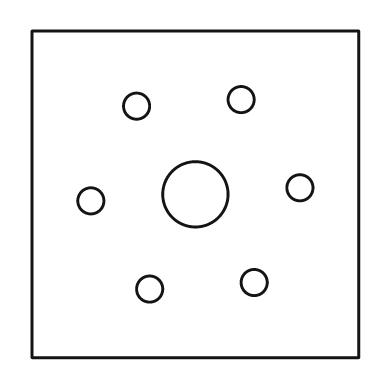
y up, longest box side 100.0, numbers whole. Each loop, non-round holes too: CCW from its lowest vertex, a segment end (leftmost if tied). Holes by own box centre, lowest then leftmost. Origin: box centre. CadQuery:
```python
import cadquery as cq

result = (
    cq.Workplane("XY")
    .moveTo(-50.0, -50.0)
    .lineTo(50.0, -50.0)
    .lineTo(50.0, 50.0)
    .lineTo(-50.0, 50.0)
    .close()
    .moveTo(-14.0, -29.0)
    .circle(4.0)
    .moveTo(18.0, -27.0)
    .circle(4.0)
    .moveTo(-32.0, -2.0)
    .circle(4.0)
    .moveTo(0.0, 0.0)
    .circle(10.0)
    .moveTo(32.0, 2.0)
    .circle(4.0)
    .moveTo(-18.0, 27.0)
    .circle(4.0)
    .moveTo(14.0, 29.0)
    .circle(4.0)
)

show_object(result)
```